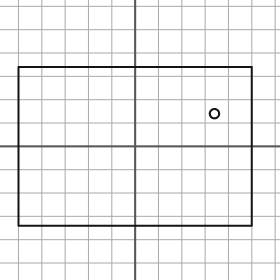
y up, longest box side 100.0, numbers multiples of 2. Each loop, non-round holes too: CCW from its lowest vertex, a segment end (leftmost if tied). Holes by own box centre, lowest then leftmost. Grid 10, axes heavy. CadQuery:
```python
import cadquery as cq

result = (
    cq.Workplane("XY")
    .moveTo(-50.0, -34.0)
    .lineTo(50.0, -34.0)
    .lineTo(50.0, 34.0)
    .lineTo(-50.0, 34.0)
    .close()
    .moveTo(34.0, 14.0)
    .circle(2.0)
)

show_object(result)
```